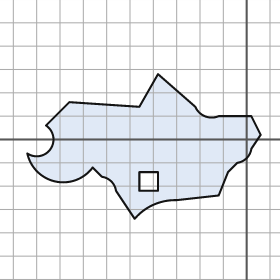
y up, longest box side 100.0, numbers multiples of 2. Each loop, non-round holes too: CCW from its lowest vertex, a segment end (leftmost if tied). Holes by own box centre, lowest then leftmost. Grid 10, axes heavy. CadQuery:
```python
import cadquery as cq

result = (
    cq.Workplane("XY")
    .moveTo(-48.0, -34.0)
    .threePointArc((-40.0, -28.0), (-30.0, -26.0))
    .lineTo(-12.0, -24.0)
    .lineTo(-8.0, -14.0)
    .lineTo(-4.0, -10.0)
    .threePointArc((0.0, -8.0), (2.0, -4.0))
    .lineTo(6.0, 2.0)
    .lineTo(2.0, 10.0)
    .lineTo(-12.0, 10.0)
    .threePointArc((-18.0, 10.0), (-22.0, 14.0))
    .lineTo(-38.0, 28.0)
    .lineTo(-46.0, 14.0)
    .lineTo(-76.0, 16.0)
    .lineTo(-86.0, 6.0)
    .threePointArc((-84.0, -4.0), (-94.0, -6.0))
    .threePointArc((-82.0, -18.0), (-66.0, -12.0))
    .lineTo(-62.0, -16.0)
    .threePointArc((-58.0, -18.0), (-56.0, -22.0))
    .close()
    .moveTo(-46.0, -22.0)
    .lineTo(-38.0, -22.0)
    .lineTo(-38.0, -14.0)
    .lineTo(-46.0, -14.0)
    .close()
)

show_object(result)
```